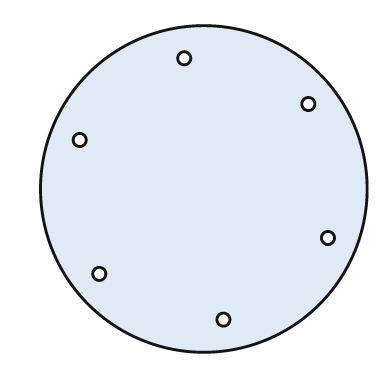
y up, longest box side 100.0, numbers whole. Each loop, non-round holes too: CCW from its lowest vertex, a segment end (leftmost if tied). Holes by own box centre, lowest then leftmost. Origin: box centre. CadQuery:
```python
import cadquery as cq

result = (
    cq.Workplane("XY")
    .moveTo(0.0, 0.0)
    .circle(50.0)
    .moveTo(6.0, -40.0)
    .circle(2.0)
    .moveTo(-32.0, -26.0)
    .circle(2.0)
    .moveTo(38.0, -15.0)
    .circle(2.0)
    .moveTo(-38.0, 15.0)
    .circle(2.0)
    .moveTo(32.0, 26.0)
    .circle(2.0)
    .moveTo(-6.0, 40.0)
    .circle(2.0)
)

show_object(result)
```